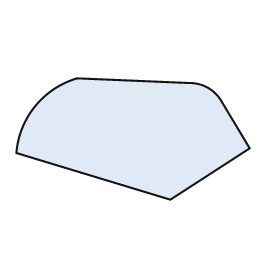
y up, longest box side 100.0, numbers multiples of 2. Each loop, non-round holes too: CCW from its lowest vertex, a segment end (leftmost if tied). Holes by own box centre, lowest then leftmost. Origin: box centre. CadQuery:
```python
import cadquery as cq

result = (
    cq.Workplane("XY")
    .moveTo(16.0, -26.0)
    .lineTo(50.0, -4.0)
    .lineTo(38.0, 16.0)
    .threePointArc((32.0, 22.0), (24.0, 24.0))
    .lineTo(-24.0, 26.0)
    .threePointArc((-42.0, 14.0), (-50.0, -6.0))
    .close()
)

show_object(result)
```